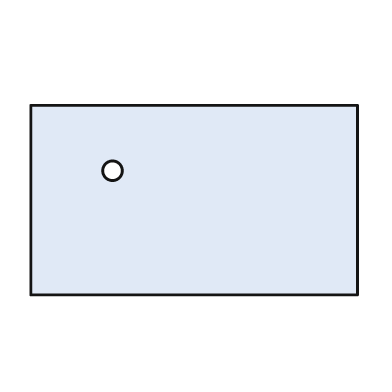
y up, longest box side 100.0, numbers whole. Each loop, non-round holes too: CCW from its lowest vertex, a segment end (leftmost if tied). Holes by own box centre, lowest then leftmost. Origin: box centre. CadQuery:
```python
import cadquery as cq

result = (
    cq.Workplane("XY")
    .moveTo(-50.0, -29.0)
    .lineTo(50.0, -29.0)
    .lineTo(50.0, 29.0)
    .lineTo(-50.0, 29.0)
    .close()
    .moveTo(-25.0, 9.0)
    .circle(3.0)
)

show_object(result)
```